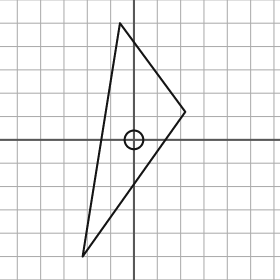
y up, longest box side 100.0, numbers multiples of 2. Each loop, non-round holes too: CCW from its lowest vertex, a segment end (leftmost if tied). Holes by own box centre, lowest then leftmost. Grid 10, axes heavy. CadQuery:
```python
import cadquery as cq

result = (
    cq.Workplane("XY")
    .moveTo(-22.0, -50.0)
    .lineTo(22.0, 12.0)
    .lineTo(-6.0, 50.0)
    .close()
    .moveTo(0.0, 0.0)
    .circle(4.0)
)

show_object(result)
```